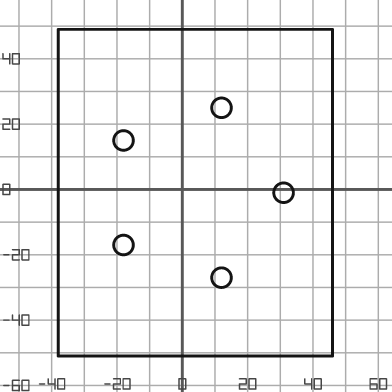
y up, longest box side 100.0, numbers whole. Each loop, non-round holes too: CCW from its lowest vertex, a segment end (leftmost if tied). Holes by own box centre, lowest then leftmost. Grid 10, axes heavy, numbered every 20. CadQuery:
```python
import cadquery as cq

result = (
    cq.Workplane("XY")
    .moveTo(-38.0, -51.0)
    .lineTo(46.0, -51.0)
    .lineTo(46.0, 49.0)
    .lineTo(-38.0, 49.0)
    .close()
    .moveTo(12.0, -27.0)
    .circle(3.0)
    .moveTo(-18.0, -17.0)
    .circle(3.0)
    .moveTo(31.0, -1.0)
    .circle(3.0)
    .moveTo(-18.0, 15.0)
    .circle(3.0)
    .moveTo(12.0, 25.0)
    .circle(3.0)
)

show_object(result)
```